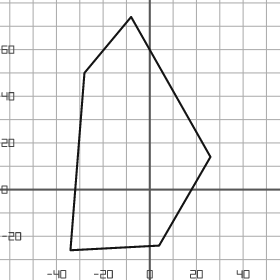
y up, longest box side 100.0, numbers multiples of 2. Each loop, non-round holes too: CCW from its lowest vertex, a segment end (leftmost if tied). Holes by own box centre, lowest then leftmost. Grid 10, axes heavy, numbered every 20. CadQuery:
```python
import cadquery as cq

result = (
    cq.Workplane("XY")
    .moveTo(-34.0, -26.0)
    .lineTo(4.0, -24.0)
    .lineTo(26.0, 14.0)
    .lineTo(-8.0, 74.0)
    .lineTo(-28.0, 50.0)
    .close()
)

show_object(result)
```